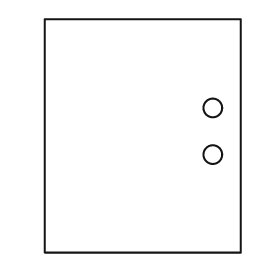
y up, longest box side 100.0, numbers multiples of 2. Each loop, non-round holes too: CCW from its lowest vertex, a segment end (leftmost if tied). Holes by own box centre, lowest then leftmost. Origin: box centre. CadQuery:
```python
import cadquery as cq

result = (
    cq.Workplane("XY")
    .moveTo(-42.0, -50.0)
    .lineTo(42.0, -50.0)
    .lineTo(42.0, 50.0)
    .lineTo(-42.0, 50.0)
    .close()
    .moveTo(30.0, -8.0)
    .circle(4.0)
    .moveTo(30.0, 12.0)
    .circle(4.0)
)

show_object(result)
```